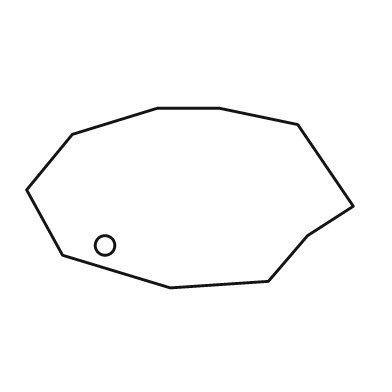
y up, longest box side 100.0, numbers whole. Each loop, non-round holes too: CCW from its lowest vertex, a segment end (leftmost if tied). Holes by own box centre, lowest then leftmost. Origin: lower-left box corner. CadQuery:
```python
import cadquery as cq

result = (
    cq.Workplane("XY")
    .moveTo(44.0, 0.0)
    .lineTo(74.0, 2.0)
    .lineTo(86.0, 16.0)
    .lineTo(100.0, 25.0)
    .lineTo(83.0, 50.0)
    .lineTo(59.0, 55.0)
    .lineTo(40.0, 55.0)
    .lineTo(14.0, 47.0)
    .lineTo(0.0, 30.0)
    .lineTo(11.0, 10.0)
    .close()
    .moveTo(24.0, 13.0)
    .circle(3.0)
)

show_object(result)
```